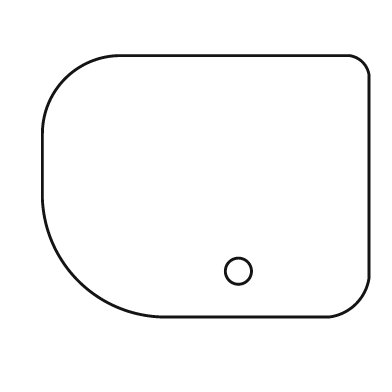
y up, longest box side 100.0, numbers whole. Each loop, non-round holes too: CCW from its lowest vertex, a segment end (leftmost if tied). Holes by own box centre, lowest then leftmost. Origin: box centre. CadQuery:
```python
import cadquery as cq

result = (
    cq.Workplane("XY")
    .moveTo(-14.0, -40.0)
    .lineTo(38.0, -40.0)
    .threePointArc((46.0, -36.0), (50.0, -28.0))
    .lineTo(50.0, 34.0)
    .threePointArc((48.0, 38.0), (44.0, 40.0))
    .lineTo(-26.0, 40.0)
    .threePointArc((-43.0, 33.0), (-50.0, 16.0))
    .lineTo(-50.0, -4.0)
    .threePointArc((-39.0, -29.0), (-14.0, -40.0))
    .close()
    .moveTo(10.0, -26.0)
    .circle(4.0)
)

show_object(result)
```